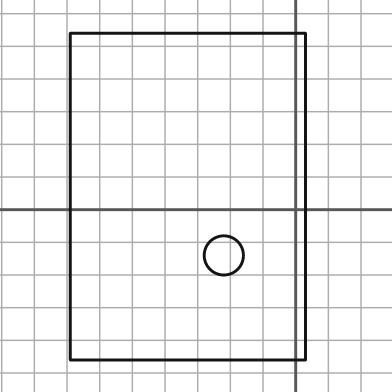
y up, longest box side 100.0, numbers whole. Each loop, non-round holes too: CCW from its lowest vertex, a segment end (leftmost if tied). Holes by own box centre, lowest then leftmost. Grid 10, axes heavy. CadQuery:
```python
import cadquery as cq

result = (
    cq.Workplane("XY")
    .moveTo(-69.0, -46.0)
    .lineTo(3.0, -46.0)
    .lineTo(3.0, 54.0)
    .lineTo(-69.0, 54.0)
    .close()
    .moveTo(-22.0, -14.0)
    .circle(6.0)
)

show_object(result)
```